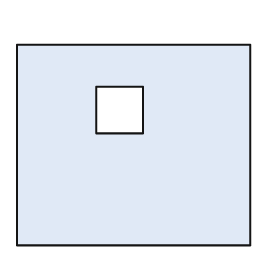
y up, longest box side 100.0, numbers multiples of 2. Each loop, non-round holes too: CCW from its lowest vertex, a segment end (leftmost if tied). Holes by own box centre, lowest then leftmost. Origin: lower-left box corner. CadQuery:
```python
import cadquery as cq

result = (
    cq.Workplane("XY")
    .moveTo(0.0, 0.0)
    .lineTo(100.0, 0.0)
    .lineTo(100.0, 86.0)
    .lineTo(0.0, 86.0)
    .close()
    .moveTo(34.0, 48.0)
    .lineTo(54.0, 48.0)
    .lineTo(54.0, 68.0)
    .lineTo(34.0, 68.0)
    .close()
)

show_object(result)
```